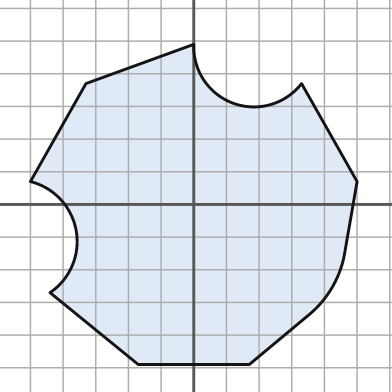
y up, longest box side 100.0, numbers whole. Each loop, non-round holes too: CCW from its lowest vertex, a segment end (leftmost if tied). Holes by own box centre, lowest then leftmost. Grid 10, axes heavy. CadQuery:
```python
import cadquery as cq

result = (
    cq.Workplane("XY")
    .moveTo(-17.0, -49.0)
    .lineTo(17.0, -49.0)
    .lineTo(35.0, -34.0)
    .threePointArc((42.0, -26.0), (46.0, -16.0))
    .lineTo(50.0, 7.0)
    .lineTo(33.0, 37.0)
    .threePointArc((12.0, 31.0), (0.0, 49.0))
    .lineTo(-33.0, 37.0)
    .lineTo(-50.0, 7.0)
    .threePointArc((-36.0, -8.0), (-44.0, -27.0))
    .close()
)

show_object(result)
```